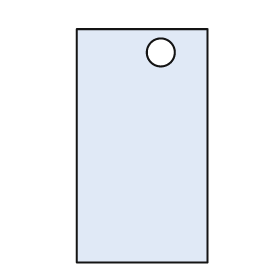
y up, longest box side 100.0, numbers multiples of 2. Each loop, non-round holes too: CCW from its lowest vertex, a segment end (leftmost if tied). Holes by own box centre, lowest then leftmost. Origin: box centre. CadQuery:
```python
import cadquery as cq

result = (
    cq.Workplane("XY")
    .moveTo(-28.0, -50.0)
    .lineTo(28.0, -50.0)
    .lineTo(28.0, 50.0)
    .lineTo(-28.0, 50.0)
    .close()
    .moveTo(8.0, 40.0)
    .circle(6.0)
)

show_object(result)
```